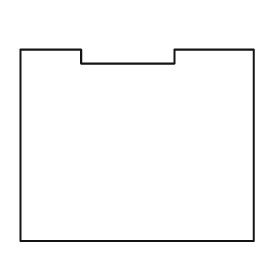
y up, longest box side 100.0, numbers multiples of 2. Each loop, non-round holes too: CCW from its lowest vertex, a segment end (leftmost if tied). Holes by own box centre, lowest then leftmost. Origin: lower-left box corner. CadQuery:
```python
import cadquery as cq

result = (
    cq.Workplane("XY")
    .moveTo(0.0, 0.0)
    .lineTo(100.0, 0.0)
    .lineTo(100.0, 82.0)
    .lineTo(66.0, 82.0)
    .lineTo(66.0, 76.0)
    .lineTo(26.0, 76.0)
    .lineTo(26.0, 82.0)
    .lineTo(0.0, 82.0)
    .close()
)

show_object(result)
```